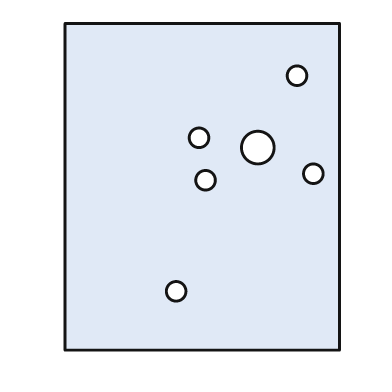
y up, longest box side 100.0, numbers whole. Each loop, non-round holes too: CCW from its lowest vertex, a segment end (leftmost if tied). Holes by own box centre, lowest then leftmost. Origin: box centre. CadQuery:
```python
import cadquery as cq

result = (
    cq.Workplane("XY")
    .moveTo(-42.0, -50.0)
    .lineTo(42.0, -50.0)
    .lineTo(42.0, 50.0)
    .lineTo(-42.0, 50.0)
    .close()
    .moveTo(-8.0, -32.0)
    .circle(3.0)
    .moveTo(1.0, 2.0)
    .circle(3.0)
    .moveTo(34.0, 4.0)
    .circle(3.0)
    .moveTo(17.0, 12.0)
    .circle(5.0)
    .moveTo(-1.0, 15.0)
    .circle(3.0)
    .moveTo(29.0, 34.0)
    .circle(3.0)
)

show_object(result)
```